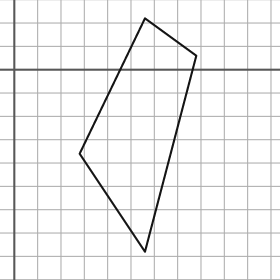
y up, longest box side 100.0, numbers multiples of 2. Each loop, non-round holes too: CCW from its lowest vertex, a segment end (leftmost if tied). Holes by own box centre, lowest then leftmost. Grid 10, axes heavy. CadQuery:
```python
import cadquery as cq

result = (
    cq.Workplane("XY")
    .moveTo(56.0, -78.0)
    .lineTo(78.0, 6.0)
    .lineTo(56.0, 22.0)
    .lineTo(28.0, -36.0)
    .close()
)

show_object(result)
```